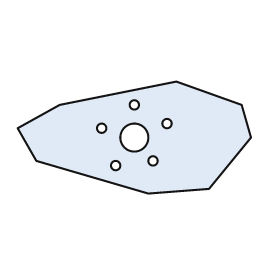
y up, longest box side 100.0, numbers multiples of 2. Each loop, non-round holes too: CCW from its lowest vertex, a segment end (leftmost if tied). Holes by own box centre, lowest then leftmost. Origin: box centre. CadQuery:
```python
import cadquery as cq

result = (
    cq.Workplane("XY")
    .moveTo(6.0, -24.0)
    .lineTo(32.0, -22.0)
    .lineTo(50.0, 0.0)
    .lineTo(46.0, 14.0)
    .lineTo(18.0, 24.0)
    .lineTo(-32.0, 14.0)
    .lineTo(-50.0, 4.0)
    .lineTo(-42.0, -10.0)
    .close()
    .moveTo(-8.0, -12.0)
    .circle(2.0)
    .moveTo(8.0, -10.0)
    .circle(2.0)
    .moveTo(0.0, 0.0)
    .circle(6.0)
    .moveTo(-14.0, 4.0)
    .circle(2.0)
    .moveTo(14.0, 6.0)
    .circle(2.0)
    .moveTo(0.0, 14.0)
    .circle(2.0)
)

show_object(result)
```